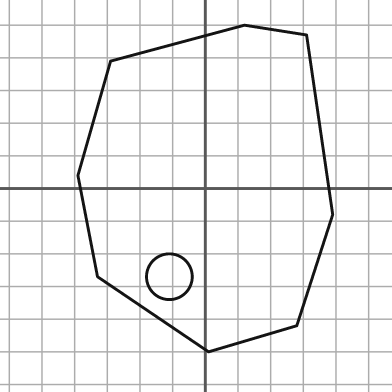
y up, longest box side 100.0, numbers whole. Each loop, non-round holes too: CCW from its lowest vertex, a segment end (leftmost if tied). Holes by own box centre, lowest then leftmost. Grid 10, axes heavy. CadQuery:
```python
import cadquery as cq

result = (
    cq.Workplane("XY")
    .moveTo(1.0, -50.0)
    .lineTo(28.0, -42.0)
    .lineTo(39.0, -8.0)
    .lineTo(31.0, 47.0)
    .lineTo(12.0, 50.0)
    .lineTo(-29.0, 39.0)
    .lineTo(-39.0, 4.0)
    .lineTo(-33.0, -27.0)
    .close()
    .moveTo(-11.0, -27.0)
    .circle(7.0)
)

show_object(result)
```